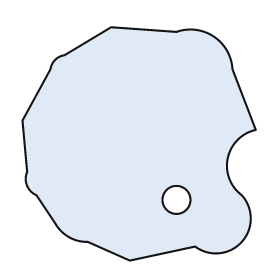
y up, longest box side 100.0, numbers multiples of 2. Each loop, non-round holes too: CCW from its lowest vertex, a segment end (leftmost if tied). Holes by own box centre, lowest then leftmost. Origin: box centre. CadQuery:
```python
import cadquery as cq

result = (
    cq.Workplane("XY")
    .moveTo(-4.0, -50.0)
    .lineTo(24.0, -44.0)
    .threePointArc((44.0, -42.0), (44.0, -22.0))
    .threePointArc((38.0, -6.0), (50.0, 6.0))
    .lineTo(40.0, 32.0)
    .threePointArc((32.0, 46.0), (16.0, 48.0))
    .lineTo(-12.0, 50.0)
    .lineTo(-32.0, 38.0)
    .threePointArc((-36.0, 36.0), (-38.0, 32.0))
    .lineTo(-50.0, 10.0)
    .lineTo(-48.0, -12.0)
    .threePointArc((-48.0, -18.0), (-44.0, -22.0))
    .lineTo(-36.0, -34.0)
    .threePointArc((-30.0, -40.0), (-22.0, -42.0))
    .close()
    .moveTo(16.0, -24.0)
    .circle(6.0)
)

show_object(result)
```